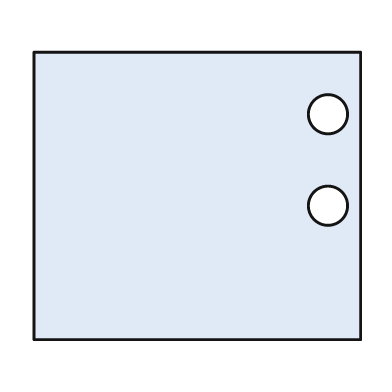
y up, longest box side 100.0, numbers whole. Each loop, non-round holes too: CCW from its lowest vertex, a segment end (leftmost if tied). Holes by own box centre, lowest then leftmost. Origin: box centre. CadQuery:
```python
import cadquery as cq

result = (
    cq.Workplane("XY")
    .moveTo(-50.0, -44.0)
    .lineTo(50.0, -44.0)
    .lineTo(50.0, 44.0)
    .lineTo(-50.0, 44.0)
    .close()
    .moveTo(40.0, -3.0)
    .circle(6.0)
    .moveTo(40.0, 25.0)
    .circle(6.0)
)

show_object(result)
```